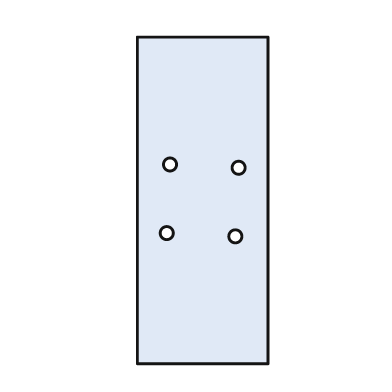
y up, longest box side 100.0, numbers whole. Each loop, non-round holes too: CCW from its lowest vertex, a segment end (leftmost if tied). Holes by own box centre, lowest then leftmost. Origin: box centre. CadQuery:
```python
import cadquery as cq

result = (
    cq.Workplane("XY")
    .moveTo(-20.0, -50.0)
    .lineTo(20.0, -50.0)
    .lineTo(20.0, 50.0)
    .lineTo(-20.0, 50.0)
    .close()
    .moveTo(10.0, -11.0)
    .circle(2.0)
    .moveTo(-11.0, -10.0)
    .circle(2.0)
    .moveTo(11.0, 10.0)
    .circle(2.0)
    .moveTo(-10.0, 11.0)
    .circle(2.0)
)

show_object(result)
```